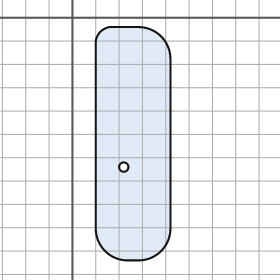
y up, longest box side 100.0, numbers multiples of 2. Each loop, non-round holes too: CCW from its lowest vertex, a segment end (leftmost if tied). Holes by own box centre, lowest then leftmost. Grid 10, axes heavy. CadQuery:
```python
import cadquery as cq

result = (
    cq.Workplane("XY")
    .moveTo(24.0, -104.0)
    .lineTo(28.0, -104.0)
    .threePointArc((38.0, -100.0), (42.0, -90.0))
    .lineTo(42.0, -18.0)
    .threePointArc((38.0, -8.0), (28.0, -4.0))
    .lineTo(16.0, -4.0)
    .threePointArc((12.0, -6.0), (10.0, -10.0))
    .lineTo(10.0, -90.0)
    .threePointArc((14.0, -100.0), (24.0, -104.0))
    .close()
    .moveTo(22.0, -64.0)
    .circle(2.0)
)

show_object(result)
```